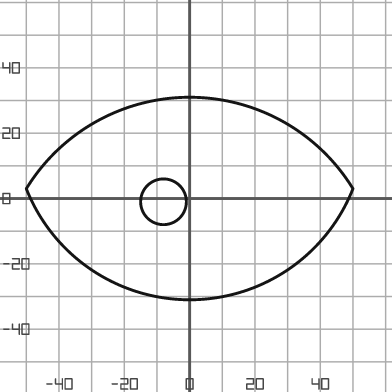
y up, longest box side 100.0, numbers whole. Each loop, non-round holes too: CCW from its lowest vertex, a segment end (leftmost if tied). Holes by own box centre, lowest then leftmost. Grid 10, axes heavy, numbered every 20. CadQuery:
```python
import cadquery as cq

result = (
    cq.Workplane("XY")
    .moveTo(-50.0, 3.0)
    .threePointArc((0.0, -31.0), (50.0, 3.0))
    .threePointArc((0.0, 31.0), (-50.0, 3.0))
    .close()
    .moveTo(-8.0, -1.0)
    .circle(7.0)
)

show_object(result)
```